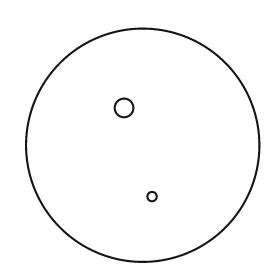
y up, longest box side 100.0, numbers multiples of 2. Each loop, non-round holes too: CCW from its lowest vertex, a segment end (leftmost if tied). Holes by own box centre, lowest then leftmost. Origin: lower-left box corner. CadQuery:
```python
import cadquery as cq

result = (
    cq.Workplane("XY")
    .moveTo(50.0, 50.0)
    .circle(50.0)
    .moveTo(54.0, 28.0)
    .circle(2.0)
    .moveTo(42.0, 66.0)
    .circle(4.0)
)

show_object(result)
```